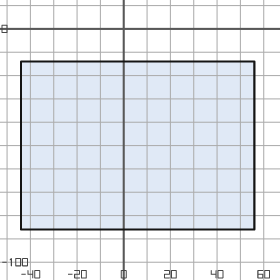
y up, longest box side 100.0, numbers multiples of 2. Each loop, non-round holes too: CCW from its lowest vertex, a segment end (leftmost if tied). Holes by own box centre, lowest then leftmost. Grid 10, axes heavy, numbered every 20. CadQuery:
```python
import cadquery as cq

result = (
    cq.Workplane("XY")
    .moveTo(-44.0, -86.0)
    .lineTo(56.0, -86.0)
    .lineTo(56.0, -14.0)
    .lineTo(-44.0, -14.0)
    .close()
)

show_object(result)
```